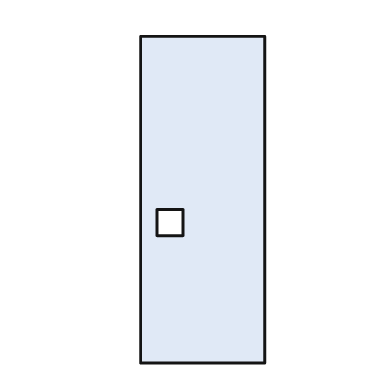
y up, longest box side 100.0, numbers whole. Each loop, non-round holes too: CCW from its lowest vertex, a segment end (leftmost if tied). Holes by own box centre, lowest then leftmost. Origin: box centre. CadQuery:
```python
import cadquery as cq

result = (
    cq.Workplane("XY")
    .moveTo(-19.0, -50.0)
    .lineTo(19.0, -50.0)
    .lineTo(19.0, 50.0)
    .lineTo(-19.0, 50.0)
    .close()
    .moveTo(-14.0, -11.0)
    .lineTo(-6.0, -11.0)
    .lineTo(-6.0, -3.0)
    .lineTo(-14.0, -3.0)
    .close()
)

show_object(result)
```